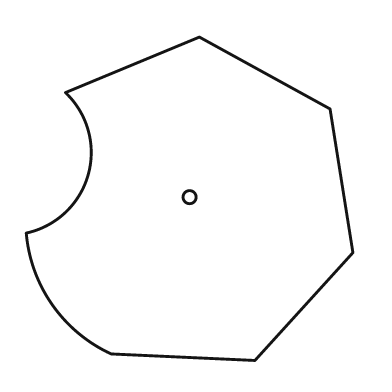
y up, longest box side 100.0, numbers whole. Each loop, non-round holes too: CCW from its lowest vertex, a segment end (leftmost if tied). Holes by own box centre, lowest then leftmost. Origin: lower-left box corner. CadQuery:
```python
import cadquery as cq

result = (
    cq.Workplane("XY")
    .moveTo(70.0, 0.0)
    .lineTo(100.0, 33.0)
    .lineTo(93.0, 77.0)
    .lineTo(53.0, 99.0)
    .lineTo(12.0, 82.0)
    .threePointArc((19.0, 57.0), (0.0, 39.0))
    .threePointArc((8.0, 17.0), (26.0, 2.0))
    .close()
    .moveTo(50.0, 50.0)
    .circle(2.0)
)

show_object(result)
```